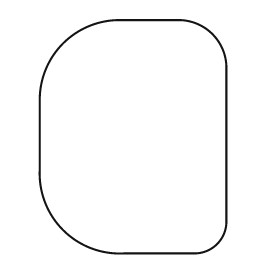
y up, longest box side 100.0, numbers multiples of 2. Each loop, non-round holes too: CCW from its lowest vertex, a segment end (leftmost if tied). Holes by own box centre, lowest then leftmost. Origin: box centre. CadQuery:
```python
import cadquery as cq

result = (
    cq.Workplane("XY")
    .moveTo(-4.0, -50.0)
    .lineTo(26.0, -50.0)
    .threePointArc((36.0, -46.0), (40.0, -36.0))
    .lineTo(40.0, 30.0)
    .threePointArc((34.0, 44.0), (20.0, 50.0))
    .lineTo(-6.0, 50.0)
    .threePointArc((-30.0, 40.0), (-40.0, 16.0))
    .lineTo(-40.0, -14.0)
    .threePointArc((-30.0, -40.0), (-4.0, -50.0))
    .close()
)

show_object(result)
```